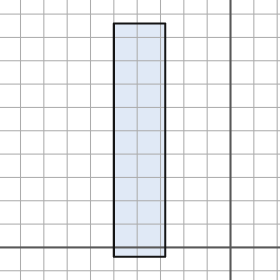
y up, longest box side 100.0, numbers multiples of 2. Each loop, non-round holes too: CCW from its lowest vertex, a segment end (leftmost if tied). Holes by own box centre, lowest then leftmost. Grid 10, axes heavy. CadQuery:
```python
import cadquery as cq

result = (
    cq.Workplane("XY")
    .moveTo(-50.0, -4.0)
    .lineTo(-28.0, -4.0)
    .lineTo(-28.0, 96.0)
    .lineTo(-50.0, 96.0)
    .close()
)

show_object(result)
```